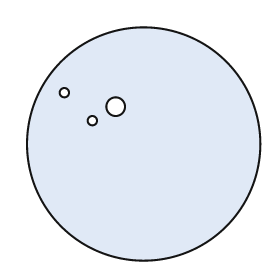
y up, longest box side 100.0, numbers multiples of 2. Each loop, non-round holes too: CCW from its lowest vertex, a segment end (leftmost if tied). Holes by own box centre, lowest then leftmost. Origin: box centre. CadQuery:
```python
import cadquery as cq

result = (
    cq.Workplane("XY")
    .moveTo(0.0, 0.0)
    .circle(50.0)
    .moveTo(-22.0, 10.0)
    .circle(2.0)
    .moveTo(-12.0, 16.0)
    .circle(4.0)
    .moveTo(-34.0, 22.0)
    .circle(2.0)
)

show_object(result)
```